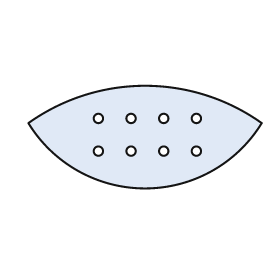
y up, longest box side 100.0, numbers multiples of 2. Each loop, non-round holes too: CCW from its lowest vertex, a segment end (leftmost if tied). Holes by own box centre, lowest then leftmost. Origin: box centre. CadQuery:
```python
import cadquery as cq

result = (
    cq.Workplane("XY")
    .moveTo(-50.0, 6.0)
    .threePointArc((0.0, -22.0), (50.0, 6.0))
    .threePointArc((0.0, 22.0), (-50.0, 6.0))
    .close()
    .moveTo(-20.0, -6.0)
    .circle(2.0)
    .moveTo(-6.0, -6.0)
    .circle(2.0)
    .moveTo(8.0, -6.0)
    .circle(2.0)
    .moveTo(22.0, -6.0)
    .circle(2.0)
    .moveTo(-20.0, 8.0)
    .circle(2.0)
    .moveTo(-6.0, 8.0)
    .circle(2.0)
    .moveTo(8.0, 8.0)
    .circle(2.0)
    .moveTo(22.0, 8.0)
    .circle(2.0)
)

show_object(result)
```